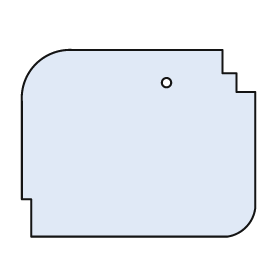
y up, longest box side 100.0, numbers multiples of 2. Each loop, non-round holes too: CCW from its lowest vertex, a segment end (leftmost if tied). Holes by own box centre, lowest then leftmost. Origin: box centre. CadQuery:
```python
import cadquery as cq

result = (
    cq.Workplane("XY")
    .moveTo(-46.0, -40.0)
    .lineTo(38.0, -40.0)
    .threePointArc((46.0, -36.0), (50.0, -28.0))
    .lineTo(50.0, 22.0)
    .lineTo(42.0, 22.0)
    .lineTo(42.0, 30.0)
    .lineTo(36.0, 30.0)
    .lineTo(36.0, 40.0)
    .lineTo(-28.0, 40.0)
    .threePointArc((-44.0, 34.0), (-50.0, 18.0))
    .lineTo(-50.0, -24.0)
    .lineTo(-46.0, -24.0)
    .close()
    .moveTo(12.0, 26.0)
    .circle(2.0)
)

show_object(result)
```